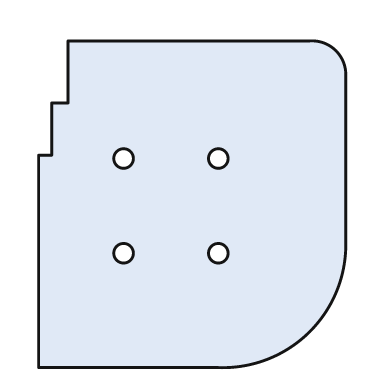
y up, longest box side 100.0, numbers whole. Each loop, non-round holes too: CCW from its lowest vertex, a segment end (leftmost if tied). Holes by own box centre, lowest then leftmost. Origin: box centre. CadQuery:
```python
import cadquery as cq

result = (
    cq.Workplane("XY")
    .moveTo(-47.0, -50.0)
    .lineTo(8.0, -50.0)
    .threePointArc((36.0, -39.0), (47.0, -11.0))
    .lineTo(47.0, 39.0)
    .threePointArc((44.0, 47.0), (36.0, 50.0))
    .lineTo(-38.0, 50.0)
    .lineTo(-38.0, 31.0)
    .lineTo(-43.0, 31.0)
    .lineTo(-43.0, 15.0)
    .lineTo(-47.0, 15.0)
    .close()
    .moveTo(-21.0, -15.0)
    .circle(3.0)
    .moveTo(8.0, -15.0)
    .circle(3.0)
    .moveTo(-21.0, 14.0)
    .circle(3.0)
    .moveTo(8.0, 14.0)
    .circle(3.0)
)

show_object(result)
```